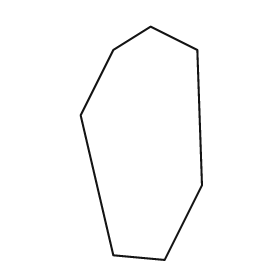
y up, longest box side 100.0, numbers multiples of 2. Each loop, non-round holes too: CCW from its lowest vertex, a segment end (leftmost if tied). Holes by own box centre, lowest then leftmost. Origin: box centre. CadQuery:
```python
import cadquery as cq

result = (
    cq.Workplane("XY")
    .moveTo(10.0, -50.0)
    .lineTo(26.0, -18.0)
    .lineTo(24.0, 40.0)
    .lineTo(4.0, 50.0)
    .lineTo(-12.0, 40.0)
    .lineTo(-26.0, 12.0)
    .lineTo(-12.0, -48.0)
    .close()
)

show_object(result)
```